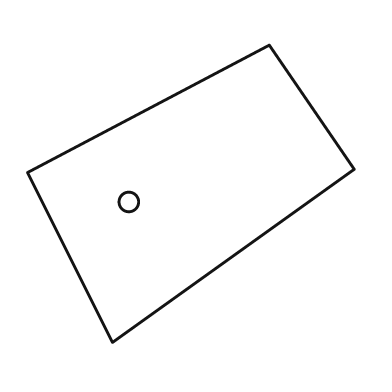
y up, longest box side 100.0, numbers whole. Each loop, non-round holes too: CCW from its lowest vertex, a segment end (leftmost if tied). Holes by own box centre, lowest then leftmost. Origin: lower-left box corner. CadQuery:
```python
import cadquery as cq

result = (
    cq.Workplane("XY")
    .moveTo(26.0, 0.0)
    .lineTo(100.0, 53.0)
    .lineTo(74.0, 91.0)
    .lineTo(0.0, 52.0)
    .close()
    .moveTo(31.0, 43.0)
    .circle(3.0)
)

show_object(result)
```